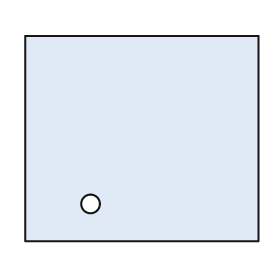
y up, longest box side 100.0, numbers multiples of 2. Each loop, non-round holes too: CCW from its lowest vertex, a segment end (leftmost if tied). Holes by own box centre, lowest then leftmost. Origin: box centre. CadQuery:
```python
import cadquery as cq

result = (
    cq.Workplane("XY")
    .moveTo(-50.0, -44.0)
    .lineTo(50.0, -44.0)
    .lineTo(50.0, 44.0)
    .lineTo(-50.0, 44.0)
    .close()
    .moveTo(-22.0, -28.0)
    .circle(4.0)
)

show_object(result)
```